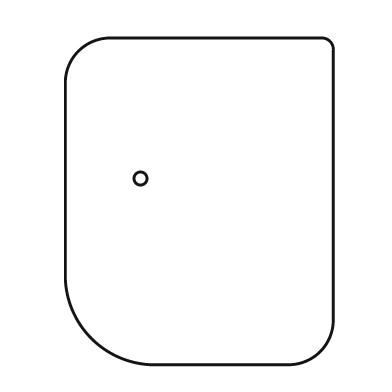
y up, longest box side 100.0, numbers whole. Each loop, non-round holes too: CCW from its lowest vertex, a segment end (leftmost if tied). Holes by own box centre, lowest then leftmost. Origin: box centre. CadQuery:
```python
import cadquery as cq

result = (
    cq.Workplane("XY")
    .moveTo(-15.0, -50.0)
    .lineTo(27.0, -50.0)
    .threePointArc((37.0, -46.0), (41.0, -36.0))
    .lineTo(41.0, 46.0)
    .threePointArc((40.0, 49.0), (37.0, 50.0))
    .lineTo(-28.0, 50.0)
    .threePointArc((-37.0, 46.0), (-41.0, 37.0))
    .lineTo(-41.0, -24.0)
    .threePointArc((-33.0, -42.0), (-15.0, -50.0))
    .close()
    .moveTo(-18.0, 7.0)
    .circle(2.0)
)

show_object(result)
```